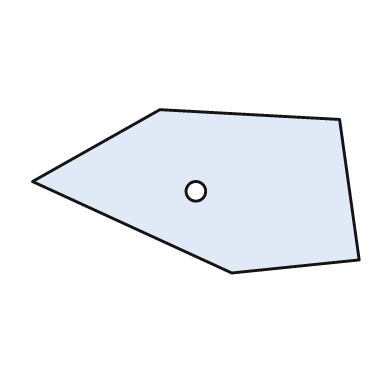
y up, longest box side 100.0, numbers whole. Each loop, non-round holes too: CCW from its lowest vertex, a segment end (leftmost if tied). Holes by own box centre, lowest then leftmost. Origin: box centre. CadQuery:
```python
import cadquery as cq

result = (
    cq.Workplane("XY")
    .moveTo(11.0, -25.0)
    .lineTo(50.0, -21.0)
    .lineTo(44.0, 22.0)
    .lineTo(-11.0, 25.0)
    .lineTo(-50.0, 3.0)
    .close()
    .moveTo(0.0, 0.0)
    .circle(3.0)
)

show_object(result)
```